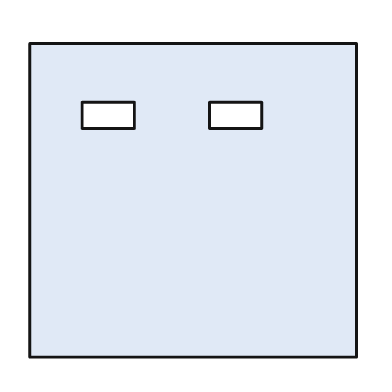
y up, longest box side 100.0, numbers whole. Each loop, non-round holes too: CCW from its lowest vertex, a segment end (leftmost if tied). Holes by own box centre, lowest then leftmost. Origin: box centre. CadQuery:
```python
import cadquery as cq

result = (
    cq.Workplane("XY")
    .moveTo(-50.0, -48.0)
    .lineTo(50.0, -48.0)
    .lineTo(50.0, 48.0)
    .lineTo(-50.0, 48.0)
    .close()
    .moveTo(-34.0, 22.0)
    .lineTo(-18.0, 22.0)
    .lineTo(-18.0, 30.0)
    .lineTo(-34.0, 30.0)
    .close()
    .moveTo(5.0, 22.0)
    .lineTo(21.0, 22.0)
    .lineTo(21.0, 30.0)
    .lineTo(5.0, 30.0)
    .close()
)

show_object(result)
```